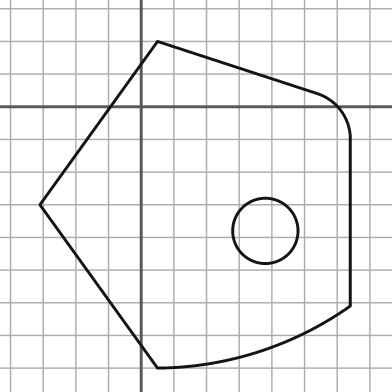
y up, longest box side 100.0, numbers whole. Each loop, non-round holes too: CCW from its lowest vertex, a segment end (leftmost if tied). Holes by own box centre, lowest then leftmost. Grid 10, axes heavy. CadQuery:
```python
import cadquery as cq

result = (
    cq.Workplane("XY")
    .moveTo(5.0, -80.0)
    .threePointArc((36.0, -75.0), (64.0, -61.0))
    .lineTo(64.0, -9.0)
    .threePointArc((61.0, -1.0), (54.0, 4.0))
    .lineTo(5.0, 20.0)
    .lineTo(-31.0, -30.0)
    .close()
    .moveTo(38.0, -38.0)
    .circle(10.0)
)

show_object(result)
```